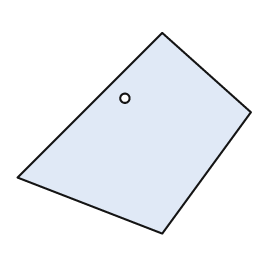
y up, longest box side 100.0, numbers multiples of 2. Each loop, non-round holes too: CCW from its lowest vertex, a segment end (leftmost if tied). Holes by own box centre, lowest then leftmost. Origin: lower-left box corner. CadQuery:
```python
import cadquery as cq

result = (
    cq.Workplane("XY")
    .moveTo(62.0, 0.0)
    .lineTo(100.0, 52.0)
    .lineTo(62.0, 86.0)
    .lineTo(0.0, 24.0)
    .close()
    .moveTo(46.0, 58.0)
    .circle(2.0)
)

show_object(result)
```